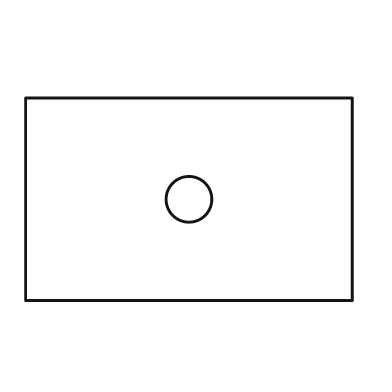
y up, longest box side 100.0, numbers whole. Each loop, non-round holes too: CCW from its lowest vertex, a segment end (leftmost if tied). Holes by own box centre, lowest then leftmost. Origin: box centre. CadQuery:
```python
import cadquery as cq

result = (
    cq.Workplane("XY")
    .moveTo(-50.0, -31.0)
    .lineTo(50.0, -31.0)
    .lineTo(50.0, 31.0)
    .lineTo(-50.0, 31.0)
    .close()
    .moveTo(0.0, 0.0)
    .circle(7.0)
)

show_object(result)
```